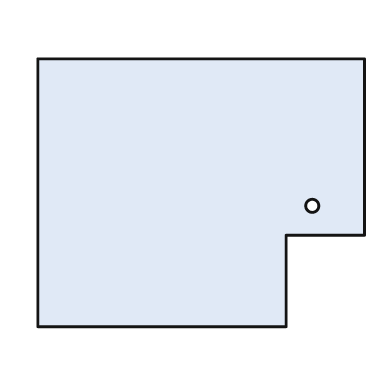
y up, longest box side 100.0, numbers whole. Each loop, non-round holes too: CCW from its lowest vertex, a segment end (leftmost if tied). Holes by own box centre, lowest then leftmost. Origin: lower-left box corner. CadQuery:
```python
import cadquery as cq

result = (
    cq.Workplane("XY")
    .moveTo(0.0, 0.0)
    .lineTo(76.0, 0.0)
    .lineTo(76.0, 28.0)
    .lineTo(100.0, 28.0)
    .lineTo(100.0, 82.0)
    .lineTo(0.0, 82.0)
    .close()
    .moveTo(84.0, 37.0)
    .circle(2.0)
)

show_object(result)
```